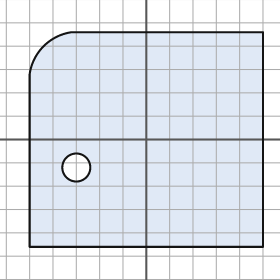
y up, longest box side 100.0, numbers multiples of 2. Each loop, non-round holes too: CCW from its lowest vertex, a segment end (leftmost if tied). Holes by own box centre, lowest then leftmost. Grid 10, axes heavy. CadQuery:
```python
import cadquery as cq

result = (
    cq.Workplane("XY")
    .moveTo(-50.0, -46.0)
    .lineTo(50.0, -46.0)
    .lineTo(50.0, 46.0)
    .lineTo(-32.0, 46.0)
    .threePointArc((-44.0, 40.0), (-50.0, 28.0))
    .close()
    .moveTo(-30.0, -12.0)
    .circle(6.0)
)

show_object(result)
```